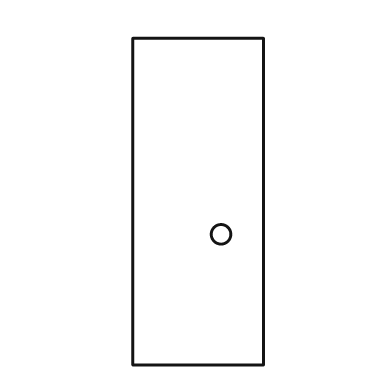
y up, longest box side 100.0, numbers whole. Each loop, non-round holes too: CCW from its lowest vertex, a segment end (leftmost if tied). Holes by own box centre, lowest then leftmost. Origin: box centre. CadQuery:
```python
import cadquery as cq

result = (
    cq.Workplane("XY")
    .moveTo(-20.0, -50.0)
    .lineTo(20.0, -50.0)
    .lineTo(20.0, 50.0)
    .lineTo(-20.0, 50.0)
    .close()
    .moveTo(7.0, -10.0)
    .circle(3.0)
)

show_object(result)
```